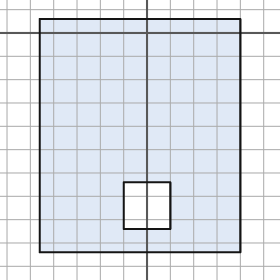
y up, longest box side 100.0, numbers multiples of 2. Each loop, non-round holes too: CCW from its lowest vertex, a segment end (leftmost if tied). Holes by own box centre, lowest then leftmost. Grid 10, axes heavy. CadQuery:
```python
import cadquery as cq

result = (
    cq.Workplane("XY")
    .moveTo(-46.0, -94.0)
    .lineTo(40.0, -94.0)
    .lineTo(40.0, 6.0)
    .lineTo(-46.0, 6.0)
    .close()
    .moveTo(-10.0, -84.0)
    .lineTo(10.0, -84.0)
    .lineTo(10.0, -64.0)
    .lineTo(-10.0, -64.0)
    .close()
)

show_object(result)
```